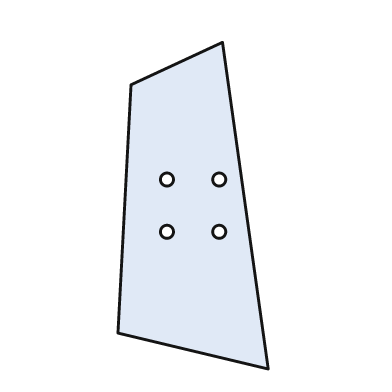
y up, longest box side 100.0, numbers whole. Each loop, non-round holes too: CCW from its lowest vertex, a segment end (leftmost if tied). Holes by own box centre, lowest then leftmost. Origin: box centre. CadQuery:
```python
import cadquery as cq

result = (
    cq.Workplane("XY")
    .moveTo(23.0, -50.0)
    .lineTo(9.0, 50.0)
    .lineTo(-19.0, 37.0)
    .lineTo(-23.0, -39.0)
    .close()
    .moveTo(-8.0, -8.0)
    .circle(2.0)
    .moveTo(8.0, -8.0)
    .circle(2.0)
    .moveTo(-8.0, 8.0)
    .circle(2.0)
    .moveTo(8.0, 8.0)
    .circle(2.0)
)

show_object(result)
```